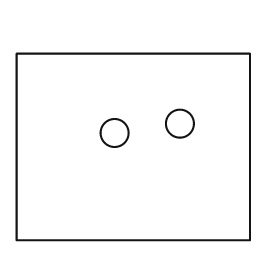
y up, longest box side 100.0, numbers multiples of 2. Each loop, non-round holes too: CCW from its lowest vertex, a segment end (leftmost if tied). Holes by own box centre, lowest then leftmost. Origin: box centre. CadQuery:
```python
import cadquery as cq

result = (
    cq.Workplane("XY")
    .moveTo(-50.0, -40.0)
    .lineTo(50.0, -40.0)
    .lineTo(50.0, 40.0)
    .lineTo(-50.0, 40.0)
    .close()
    .moveTo(-8.0, 6.0)
    .circle(6.0)
    .moveTo(20.0, 10.0)
    .circle(6.0)
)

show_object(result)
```